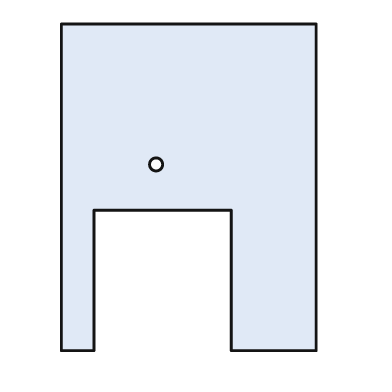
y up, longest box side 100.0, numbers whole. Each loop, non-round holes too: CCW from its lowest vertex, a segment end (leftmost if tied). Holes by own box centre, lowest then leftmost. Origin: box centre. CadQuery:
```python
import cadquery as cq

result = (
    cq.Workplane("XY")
    .moveTo(-39.0, -50.0)
    .lineTo(-29.0, -50.0)
    .lineTo(-29.0, -7.0)
    .lineTo(13.0, -7.0)
    .lineTo(13.0, -50.0)
    .lineTo(39.0, -50.0)
    .lineTo(39.0, 50.0)
    .lineTo(-39.0, 50.0)
    .close()
    .moveTo(-10.0, 7.0)
    .circle(2.0)
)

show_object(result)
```